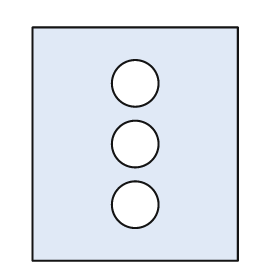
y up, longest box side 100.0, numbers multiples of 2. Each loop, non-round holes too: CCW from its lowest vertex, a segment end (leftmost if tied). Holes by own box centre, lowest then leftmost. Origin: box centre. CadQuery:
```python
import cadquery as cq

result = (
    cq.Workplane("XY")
    .moveTo(-44.0, -50.0)
    .lineTo(44.0, -50.0)
    .lineTo(44.0, 50.0)
    .lineTo(-44.0, 50.0)
    .close()
    .moveTo(0.0, -26.0)
    .circle(10.0)
    .moveTo(0.0, 0.0)
    .circle(10.0)
    .moveTo(0.0, 26.0)
    .circle(10.0)
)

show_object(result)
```